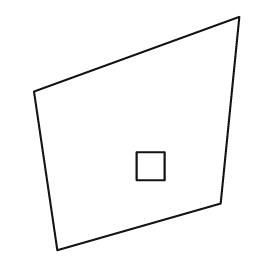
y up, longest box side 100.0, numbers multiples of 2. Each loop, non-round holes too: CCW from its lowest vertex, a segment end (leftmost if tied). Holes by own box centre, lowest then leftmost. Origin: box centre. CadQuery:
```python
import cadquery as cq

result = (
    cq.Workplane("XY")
    .moveTo(-34.0, -50.0)
    .lineTo(36.0, -30.0)
    .lineTo(44.0, 50.0)
    .lineTo(-44.0, 18.0)
    .close()
    .moveTo(0.0, -20.0)
    .lineTo(12.0, -20.0)
    .lineTo(12.0, -8.0)
    .lineTo(0.0, -8.0)
    .close()
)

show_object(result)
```